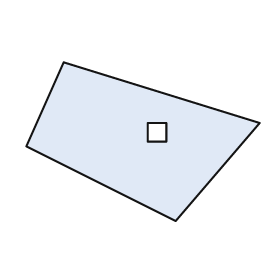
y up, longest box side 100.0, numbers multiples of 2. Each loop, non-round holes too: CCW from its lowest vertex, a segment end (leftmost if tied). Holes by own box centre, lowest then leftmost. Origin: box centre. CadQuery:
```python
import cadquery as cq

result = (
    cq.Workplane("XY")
    .moveTo(14.0, -34.0)
    .lineTo(50.0, 8.0)
    .lineTo(-34.0, 34.0)
    .lineTo(-50.0, -2.0)
    .close()
    .moveTo(2.0, 0.0)
    .lineTo(10.0, 0.0)
    .lineTo(10.0, 8.0)
    .lineTo(2.0, 8.0)
    .close()
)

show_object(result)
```